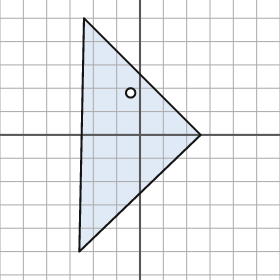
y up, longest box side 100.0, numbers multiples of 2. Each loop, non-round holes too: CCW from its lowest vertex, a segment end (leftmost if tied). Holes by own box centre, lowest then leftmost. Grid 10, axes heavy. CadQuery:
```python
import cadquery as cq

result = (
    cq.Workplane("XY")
    .moveTo(-26.0, -50.0)
    .lineTo(26.0, 0.0)
    .lineTo(-24.0, 50.0)
    .close()
    .moveTo(-4.0, 18.0)
    .circle(2.0)
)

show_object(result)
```